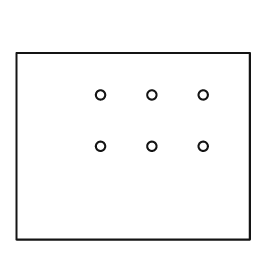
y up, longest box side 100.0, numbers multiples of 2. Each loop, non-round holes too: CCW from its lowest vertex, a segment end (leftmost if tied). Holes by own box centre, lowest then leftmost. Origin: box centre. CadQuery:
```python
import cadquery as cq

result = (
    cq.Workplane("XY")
    .moveTo(-50.0, -40.0)
    .lineTo(50.0, -40.0)
    .lineTo(50.0, 40.0)
    .lineTo(-50.0, 40.0)
    .close()
    .moveTo(-14.0, 0.0)
    .circle(2.0)
    .moveTo(8.0, 0.0)
    .circle(2.0)
    .moveTo(30.0, 0.0)
    .circle(2.0)
    .moveTo(-14.0, 22.0)
    .circle(2.0)
    .moveTo(8.0, 22.0)
    .circle(2.0)
    .moveTo(30.0, 22.0)
    .circle(2.0)
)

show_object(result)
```